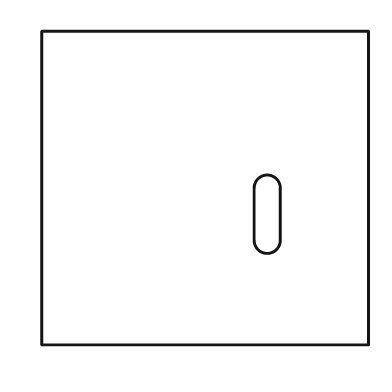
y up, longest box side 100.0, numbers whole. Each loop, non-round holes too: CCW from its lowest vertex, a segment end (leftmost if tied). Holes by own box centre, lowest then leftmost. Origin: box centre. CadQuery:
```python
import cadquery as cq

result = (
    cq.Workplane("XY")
    .moveTo(-50.0, -48.0)
    .lineTo(50.0, -48.0)
    .lineTo(50.0, 48.0)
    .lineTo(-50.0, 48.0)
    .close()
    .moveTo(15.0, -16.0)
    .threePointArc((19.0, -20.0), (23.0, -16.0))
    .lineTo(23.0, 0.0)
    .threePointArc((19.0, 4.0), (15.0, 0.0))
    .close()
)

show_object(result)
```